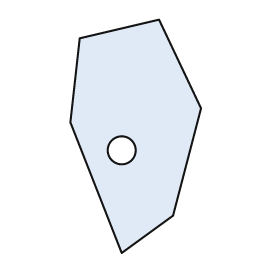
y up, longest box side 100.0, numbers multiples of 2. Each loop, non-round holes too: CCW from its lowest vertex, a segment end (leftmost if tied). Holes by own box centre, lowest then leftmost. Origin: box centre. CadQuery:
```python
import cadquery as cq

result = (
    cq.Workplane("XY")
    .moveTo(-6.0, -50.0)
    .lineTo(16.0, -34.0)
    .lineTo(28.0, 12.0)
    .lineTo(10.0, 50.0)
    .lineTo(-24.0, 42.0)
    .lineTo(-28.0, 6.0)
    .close()
    .moveTo(-6.0, -6.0)
    .circle(6.0)
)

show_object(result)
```